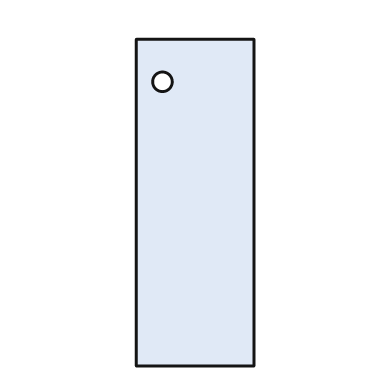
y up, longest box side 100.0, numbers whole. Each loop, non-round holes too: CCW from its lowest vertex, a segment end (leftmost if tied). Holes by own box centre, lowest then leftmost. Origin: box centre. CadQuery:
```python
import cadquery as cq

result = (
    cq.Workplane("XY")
    .moveTo(-18.0, -50.0)
    .lineTo(18.0, -50.0)
    .lineTo(18.0, 50.0)
    .lineTo(-18.0, 50.0)
    .close()
    .moveTo(-10.0, 37.0)
    .circle(3.0)
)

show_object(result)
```